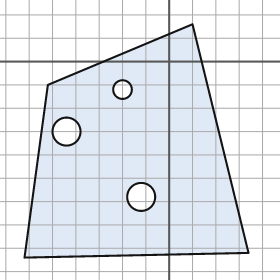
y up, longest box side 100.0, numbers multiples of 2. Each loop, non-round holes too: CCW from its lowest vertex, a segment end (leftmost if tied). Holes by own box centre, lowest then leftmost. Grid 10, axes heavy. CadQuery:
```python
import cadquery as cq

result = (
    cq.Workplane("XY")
    .moveTo(-62.0, -84.0)
    .lineTo(34.0, -82.0)
    .lineTo(10.0, 16.0)
    .lineTo(-52.0, -10.0)
    .close()
    .moveTo(-12.0, -58.0)
    .circle(6.0)
    .moveTo(-44.0, -30.0)
    .circle(6.0)
    .moveTo(-20.0, -12.0)
    .circle(4.0)
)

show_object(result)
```